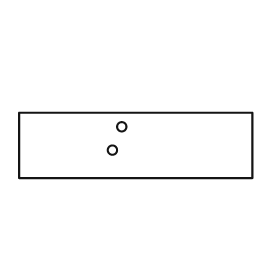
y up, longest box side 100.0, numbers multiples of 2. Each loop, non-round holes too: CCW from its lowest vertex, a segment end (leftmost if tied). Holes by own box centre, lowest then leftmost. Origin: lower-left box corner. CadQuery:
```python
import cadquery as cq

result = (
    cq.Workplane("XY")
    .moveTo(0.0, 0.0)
    .lineTo(100.0, 0.0)
    .lineTo(100.0, 28.0)
    .lineTo(0.0, 28.0)
    .close()
    .moveTo(40.0, 12.0)
    .circle(2.0)
    .moveTo(44.0, 22.0)
    .circle(2.0)
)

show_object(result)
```